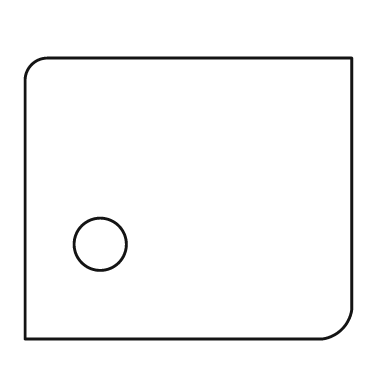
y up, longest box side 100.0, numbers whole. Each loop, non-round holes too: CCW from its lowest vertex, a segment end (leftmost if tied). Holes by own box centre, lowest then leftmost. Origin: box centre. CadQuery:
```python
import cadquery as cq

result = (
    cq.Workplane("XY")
    .moveTo(-50.0, -43.0)
    .lineTo(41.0, -43.0)
    .threePointArc((47.0, -40.0), (50.0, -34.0))
    .lineTo(50.0, 43.0)
    .lineTo(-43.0, 43.0)
    .threePointArc((-48.0, 41.0), (-50.0, 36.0))
    .close()
    .moveTo(-27.0, -14.0)
    .circle(8.0)
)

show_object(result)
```